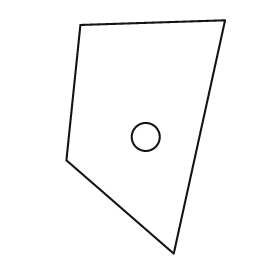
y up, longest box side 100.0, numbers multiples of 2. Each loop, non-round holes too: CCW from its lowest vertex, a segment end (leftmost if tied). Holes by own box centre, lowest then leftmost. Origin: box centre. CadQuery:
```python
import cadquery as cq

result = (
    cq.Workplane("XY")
    .moveTo(12.0, -50.0)
    .lineTo(34.0, 50.0)
    .lineTo(-28.0, 48.0)
    .lineTo(-34.0, -10.0)
    .close()
    .moveTo(0.0, 0.0)
    .circle(6.0)
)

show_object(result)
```